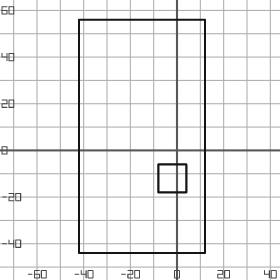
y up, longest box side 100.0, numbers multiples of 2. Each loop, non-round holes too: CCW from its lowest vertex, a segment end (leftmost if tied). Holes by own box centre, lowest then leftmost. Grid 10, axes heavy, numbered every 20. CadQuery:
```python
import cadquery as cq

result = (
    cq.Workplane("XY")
    .moveTo(-42.0, -44.0)
    .lineTo(12.0, -44.0)
    .lineTo(12.0, 56.0)
    .lineTo(-42.0, 56.0)
    .close()
    .moveTo(-8.0, -18.0)
    .lineTo(4.0, -18.0)
    .lineTo(4.0, -6.0)
    .lineTo(-8.0, -6.0)
    .close()
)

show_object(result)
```